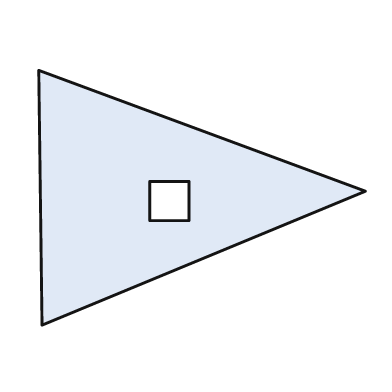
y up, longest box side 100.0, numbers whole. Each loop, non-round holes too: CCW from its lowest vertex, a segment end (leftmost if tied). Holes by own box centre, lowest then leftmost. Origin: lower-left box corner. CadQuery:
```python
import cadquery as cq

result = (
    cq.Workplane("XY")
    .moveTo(1.0, 0.0)
    .lineTo(100.0, 41.0)
    .lineTo(0.0, 78.0)
    .close()
    .moveTo(34.0, 32.0)
    .lineTo(46.0, 32.0)
    .lineTo(46.0, 44.0)
    .lineTo(34.0, 44.0)
    .close()
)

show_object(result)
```